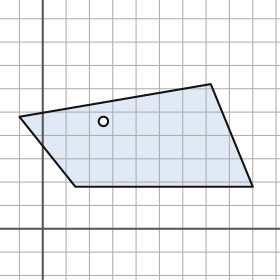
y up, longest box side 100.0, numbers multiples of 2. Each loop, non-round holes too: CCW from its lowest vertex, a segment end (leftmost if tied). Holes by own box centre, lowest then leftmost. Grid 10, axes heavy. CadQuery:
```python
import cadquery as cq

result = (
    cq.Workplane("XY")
    .moveTo(14.0, 18.0)
    .lineTo(90.0, 18.0)
    .lineTo(72.0, 62.0)
    .lineTo(-10.0, 48.0)
    .close()
    .moveTo(26.0, 46.0)
    .circle(2.0)
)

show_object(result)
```